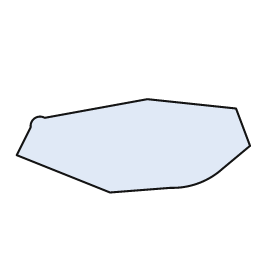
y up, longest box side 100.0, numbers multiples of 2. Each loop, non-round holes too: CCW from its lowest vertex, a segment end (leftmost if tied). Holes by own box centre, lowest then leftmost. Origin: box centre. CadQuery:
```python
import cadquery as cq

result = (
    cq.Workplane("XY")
    .moveTo(-10.0, -20.0)
    .lineTo(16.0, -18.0)
    .threePointArc((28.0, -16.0), (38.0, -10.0))
    .lineTo(50.0, 0.0)
    .lineTo(44.0, 16.0)
    .lineTo(6.0, 20.0)
    .lineTo(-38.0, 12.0)
    .threePointArc((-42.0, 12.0), (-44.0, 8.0))
    .lineTo(-50.0, -4.0)
    .close()
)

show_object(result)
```